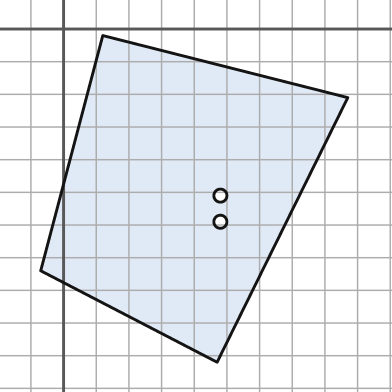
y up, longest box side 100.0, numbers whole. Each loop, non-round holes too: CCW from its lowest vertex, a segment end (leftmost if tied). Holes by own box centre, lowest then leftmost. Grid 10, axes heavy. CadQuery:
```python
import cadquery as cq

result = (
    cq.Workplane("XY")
    .moveTo(47.0, -102.0)
    .lineTo(87.0, -21.0)
    .lineTo(12.0, -2.0)
    .lineTo(-7.0, -74.0)
    .close()
    .moveTo(48.0, -59.0)
    .circle(2.0)
    .moveTo(48.0, -51.0)
    .circle(2.0)
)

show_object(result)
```